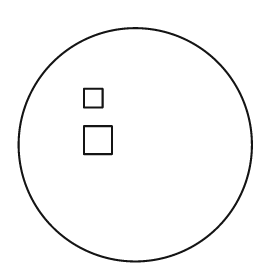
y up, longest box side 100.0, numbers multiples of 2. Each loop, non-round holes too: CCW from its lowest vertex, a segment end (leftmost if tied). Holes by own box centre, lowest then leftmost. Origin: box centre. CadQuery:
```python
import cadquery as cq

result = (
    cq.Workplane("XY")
    .moveTo(0.0, 0.0)
    .circle(50.0)
    .moveTo(-22.0, -4.0)
    .lineTo(-10.0, -4.0)
    .lineTo(-10.0, 8.0)
    .lineTo(-22.0, 8.0)
    .close()
    .moveTo(-22.0, 16.0)
    .lineTo(-14.0, 16.0)
    .lineTo(-14.0, 24.0)
    .lineTo(-22.0, 24.0)
    .close()
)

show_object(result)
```